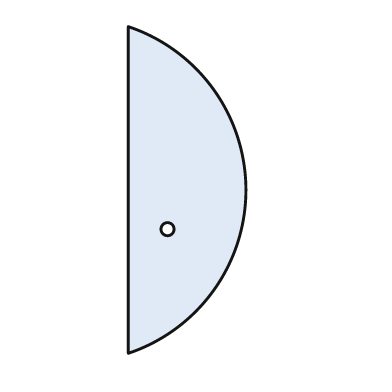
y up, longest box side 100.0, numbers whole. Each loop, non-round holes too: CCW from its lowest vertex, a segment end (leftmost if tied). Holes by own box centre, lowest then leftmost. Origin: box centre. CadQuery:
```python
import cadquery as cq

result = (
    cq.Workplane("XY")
    .moveTo(-18.0, -50.0)
    .threePointArc((18.0, 0.0), (-18.0, 50.0))
    .close()
    .moveTo(-6.0, -12.0)
    .circle(2.0)
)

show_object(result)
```